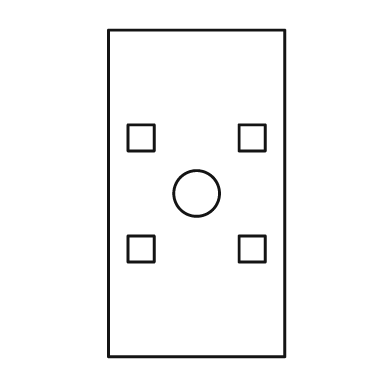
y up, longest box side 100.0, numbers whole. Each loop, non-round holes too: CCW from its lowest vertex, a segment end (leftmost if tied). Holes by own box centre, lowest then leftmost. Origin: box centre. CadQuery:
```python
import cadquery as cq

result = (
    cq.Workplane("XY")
    .moveTo(-27.0, -50.0)
    .lineTo(27.0, -50.0)
    .lineTo(27.0, 50.0)
    .lineTo(-27.0, 50.0)
    .close()
    .moveTo(-21.0, -21.0)
    .lineTo(-13.0, -21.0)
    .lineTo(-13.0, -13.0)
    .lineTo(-21.0, -13.0)
    .close()
    .moveTo(13.0, -21.0)
    .lineTo(21.0, -21.0)
    .lineTo(21.0, -13.0)
    .lineTo(13.0, -13.0)
    .close()
    .moveTo(0.0, 0.0)
    .circle(7.0)
    .moveTo(-21.0, 13.0)
    .lineTo(-13.0, 13.0)
    .lineTo(-13.0, 21.0)
    .lineTo(-21.0, 21.0)
    .close()
    .moveTo(13.0, 13.0)
    .lineTo(21.0, 13.0)
    .lineTo(21.0, 21.0)
    .lineTo(13.0, 21.0)
    .close()
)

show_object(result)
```